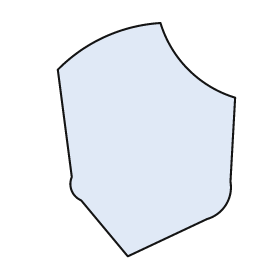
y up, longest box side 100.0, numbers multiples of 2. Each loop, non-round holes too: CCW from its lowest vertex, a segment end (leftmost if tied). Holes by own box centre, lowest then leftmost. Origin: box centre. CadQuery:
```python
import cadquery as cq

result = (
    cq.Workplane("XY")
    .moveTo(-8.0, -50.0)
    .lineTo(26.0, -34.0)
    .threePointArc((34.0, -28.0), (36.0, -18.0))
    .lineTo(38.0, 18.0)
    .threePointArc((18.0, 30.0), (6.0, 50.0))
    .threePointArc((-18.0, 44.0), (-38.0, 30.0))
    .lineTo(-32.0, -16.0)
    .threePointArc((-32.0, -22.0), (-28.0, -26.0))
    .close()
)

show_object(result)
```